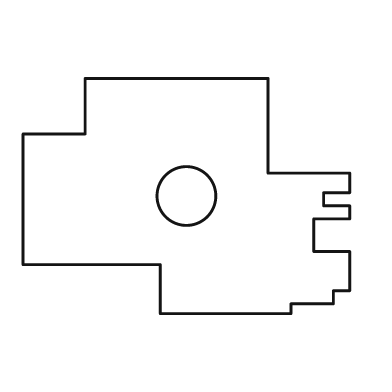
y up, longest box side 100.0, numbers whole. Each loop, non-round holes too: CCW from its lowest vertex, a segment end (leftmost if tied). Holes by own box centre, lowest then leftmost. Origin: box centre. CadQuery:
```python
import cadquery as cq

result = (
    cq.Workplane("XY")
    .moveTo(-8.0, -36.0)
    .lineTo(32.0, -36.0)
    .lineTo(32.0, -33.0)
    .lineTo(45.0, -33.0)
    .lineTo(45.0, -29.0)
    .lineTo(50.0, -29.0)
    .lineTo(50.0, -17.0)
    .lineTo(39.0, -17.0)
    .lineTo(39.0, -7.0)
    .lineTo(50.0, -7.0)
    .lineTo(50.0, -3.0)
    .lineTo(42.0, -3.0)
    .lineTo(42.0, 1.0)
    .lineTo(50.0, 1.0)
    .lineTo(50.0, 7.0)
    .lineTo(25.0, 7.0)
    .lineTo(25.0, 36.0)
    .lineTo(-31.0, 36.0)
    .lineTo(-31.0, 19.0)
    .lineTo(-50.0, 19.0)
    .lineTo(-50.0, -21.0)
    .lineTo(-8.0, -21.0)
    .close()
    .moveTo(0.0, 0.0)
    .circle(9.0)
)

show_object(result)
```